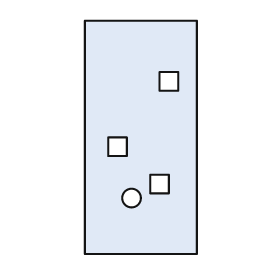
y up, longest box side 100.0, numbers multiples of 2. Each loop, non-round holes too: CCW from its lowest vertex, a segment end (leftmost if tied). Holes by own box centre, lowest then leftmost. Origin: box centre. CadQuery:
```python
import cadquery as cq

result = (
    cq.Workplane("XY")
    .moveTo(-24.0, -50.0)
    .lineTo(24.0, -50.0)
    .lineTo(24.0, 50.0)
    .lineTo(-24.0, 50.0)
    .close()
    .moveTo(-4.0, -26.0)
    .circle(4.0)
    .moveTo(4.0, -24.0)
    .lineTo(12.0, -24.0)
    .lineTo(12.0, -16.0)
    .lineTo(4.0, -16.0)
    .close()
    .moveTo(-14.0, -8.0)
    .lineTo(-6.0, -8.0)
    .lineTo(-6.0, 0.0)
    .lineTo(-14.0, 0.0)
    .close()
    .moveTo(8.0, 20.0)
    .lineTo(16.0, 20.0)
    .lineTo(16.0, 28.0)
    .lineTo(8.0, 28.0)
    .close()
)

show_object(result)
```